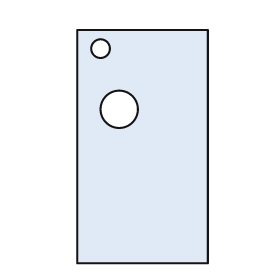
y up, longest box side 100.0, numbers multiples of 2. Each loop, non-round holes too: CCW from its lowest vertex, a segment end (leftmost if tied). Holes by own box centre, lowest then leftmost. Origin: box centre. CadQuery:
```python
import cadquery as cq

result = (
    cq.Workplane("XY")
    .moveTo(-28.0, -50.0)
    .lineTo(28.0, -50.0)
    .lineTo(28.0, 50.0)
    .lineTo(-28.0, 50.0)
    .close()
    .moveTo(-10.0, 16.0)
    .circle(8.0)
    .moveTo(-18.0, 42.0)
    .circle(4.0)
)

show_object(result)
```